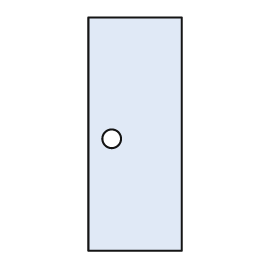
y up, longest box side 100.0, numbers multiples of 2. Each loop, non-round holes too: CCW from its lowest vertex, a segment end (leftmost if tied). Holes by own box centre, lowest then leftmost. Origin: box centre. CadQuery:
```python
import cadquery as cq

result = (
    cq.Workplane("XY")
    .moveTo(-20.0, -50.0)
    .lineTo(20.0, -50.0)
    .lineTo(20.0, 50.0)
    .lineTo(-20.0, 50.0)
    .close()
    .moveTo(-10.0, -2.0)
    .circle(4.0)
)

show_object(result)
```